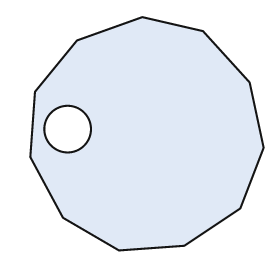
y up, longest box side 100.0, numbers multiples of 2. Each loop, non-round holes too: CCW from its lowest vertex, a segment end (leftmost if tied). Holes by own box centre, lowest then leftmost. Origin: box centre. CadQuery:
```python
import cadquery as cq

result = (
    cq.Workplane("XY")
    .moveTo(-12.0, -50.0)
    .lineTo(16.0, -48.0)
    .lineTo(40.0, -32.0)
    .lineTo(50.0, -6.0)
    .lineTo(44.0, 22.0)
    .lineTo(24.0, 44.0)
    .lineTo(-2.0, 50.0)
    .lineTo(-30.0, 40.0)
    .lineTo(-48.0, 18.0)
    .lineTo(-50.0, -10.0)
    .lineTo(-36.0, -36.0)
    .close()
    .moveTo(-34.0, 2.0)
    .circle(10.0)
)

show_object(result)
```